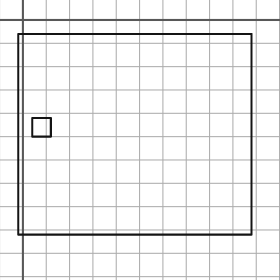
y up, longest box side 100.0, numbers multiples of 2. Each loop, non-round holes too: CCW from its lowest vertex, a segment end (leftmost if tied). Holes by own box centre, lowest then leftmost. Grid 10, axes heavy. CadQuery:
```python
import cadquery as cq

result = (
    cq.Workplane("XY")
    .moveTo(-2.0, -92.0)
    .lineTo(98.0, -92.0)
    .lineTo(98.0, -6.0)
    .lineTo(-2.0, -6.0)
    .close()
    .moveTo(4.0, -50.0)
    .lineTo(12.0, -50.0)
    .lineTo(12.0, -42.0)
    .lineTo(4.0, -42.0)
    .close()
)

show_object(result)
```